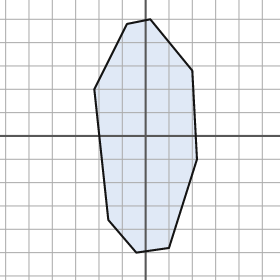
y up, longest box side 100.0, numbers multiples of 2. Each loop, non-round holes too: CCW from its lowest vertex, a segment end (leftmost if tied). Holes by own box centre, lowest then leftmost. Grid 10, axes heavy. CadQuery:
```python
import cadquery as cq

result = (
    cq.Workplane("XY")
    .moveTo(-4.0, -50.0)
    .lineTo(10.0, -48.0)
    .lineTo(22.0, -10.0)
    .lineTo(20.0, 28.0)
    .lineTo(2.0, 50.0)
    .lineTo(-8.0, 48.0)
    .lineTo(-22.0, 20.0)
    .lineTo(-16.0, -36.0)
    .close()
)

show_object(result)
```